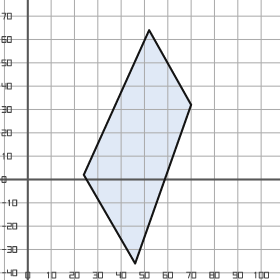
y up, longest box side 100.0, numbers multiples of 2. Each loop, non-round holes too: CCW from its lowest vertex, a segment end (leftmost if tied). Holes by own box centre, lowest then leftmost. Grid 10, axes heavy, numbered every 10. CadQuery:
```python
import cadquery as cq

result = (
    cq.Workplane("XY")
    .moveTo(46.0, -36.0)
    .lineTo(70.0, 32.0)
    .lineTo(52.0, 64.0)
    .lineTo(24.0, 2.0)
    .close()
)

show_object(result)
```